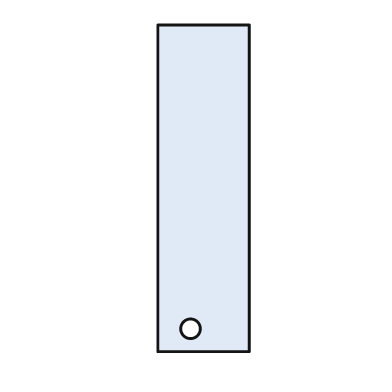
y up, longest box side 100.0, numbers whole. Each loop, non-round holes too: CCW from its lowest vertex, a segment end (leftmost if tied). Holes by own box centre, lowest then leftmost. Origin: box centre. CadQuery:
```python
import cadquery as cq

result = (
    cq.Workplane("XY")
    .moveTo(-14.0, -50.0)
    .lineTo(14.0, -50.0)
    .lineTo(14.0, 50.0)
    .lineTo(-14.0, 50.0)
    .close()
    .moveTo(-4.0, -43.0)
    .circle(3.0)
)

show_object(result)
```